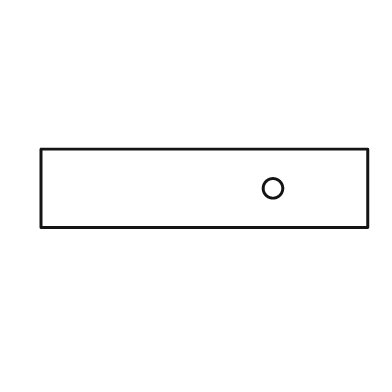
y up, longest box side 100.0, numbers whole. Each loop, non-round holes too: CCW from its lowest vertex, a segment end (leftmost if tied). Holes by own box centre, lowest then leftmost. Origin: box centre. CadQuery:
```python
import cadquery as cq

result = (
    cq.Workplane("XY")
    .moveTo(-50.0, -12.0)
    .lineTo(50.0, -12.0)
    .lineTo(50.0, 12.0)
    .lineTo(-50.0, 12.0)
    .close()
    .moveTo(21.0, 0.0)
    .circle(3.0)
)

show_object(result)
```